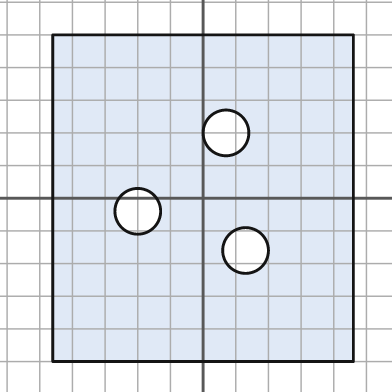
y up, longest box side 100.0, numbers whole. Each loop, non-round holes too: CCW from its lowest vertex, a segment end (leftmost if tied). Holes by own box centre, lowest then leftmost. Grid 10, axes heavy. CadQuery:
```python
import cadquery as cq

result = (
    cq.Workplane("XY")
    .moveTo(-46.0, -50.0)
    .lineTo(46.0, -50.0)
    .lineTo(46.0, 50.0)
    .lineTo(-46.0, 50.0)
    .close()
    .moveTo(13.0, -16.0)
    .circle(7.0)
    .moveTo(-20.0, -4.0)
    .circle(7.0)
    .moveTo(7.0, 20.0)
    .circle(7.0)
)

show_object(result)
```